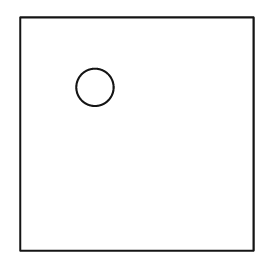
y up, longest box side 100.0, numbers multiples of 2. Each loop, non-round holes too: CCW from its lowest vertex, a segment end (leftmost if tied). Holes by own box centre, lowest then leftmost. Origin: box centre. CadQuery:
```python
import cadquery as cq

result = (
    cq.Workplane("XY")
    .moveTo(-50.0, -50.0)
    .lineTo(50.0, -50.0)
    .lineTo(50.0, 50.0)
    .lineTo(-50.0, 50.0)
    .close()
    .moveTo(-18.0, 20.0)
    .circle(8.0)
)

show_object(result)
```